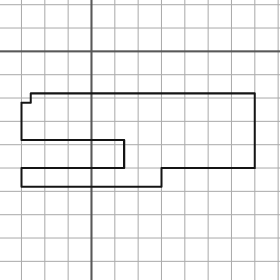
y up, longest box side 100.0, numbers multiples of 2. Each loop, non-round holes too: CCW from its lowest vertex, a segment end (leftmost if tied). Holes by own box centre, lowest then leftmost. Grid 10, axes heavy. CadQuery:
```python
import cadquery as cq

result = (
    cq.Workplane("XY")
    .moveTo(-30.0, -58.0)
    .lineTo(30.0, -58.0)
    .lineTo(30.0, -50.0)
    .lineTo(70.0, -50.0)
    .lineTo(70.0, -18.0)
    .lineTo(-26.0, -18.0)
    .lineTo(-26.0, -22.0)
    .lineTo(-30.0, -22.0)
    .lineTo(-30.0, -38.0)
    .lineTo(14.0, -38.0)
    .lineTo(14.0, -50.0)
    .lineTo(-30.0, -50.0)
    .close()
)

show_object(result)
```